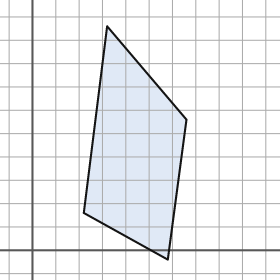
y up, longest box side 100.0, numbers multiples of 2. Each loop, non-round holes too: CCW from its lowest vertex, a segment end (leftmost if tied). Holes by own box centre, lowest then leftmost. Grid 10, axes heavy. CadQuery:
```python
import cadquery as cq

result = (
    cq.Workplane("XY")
    .moveTo(58.0, -4.0)
    .lineTo(66.0, 56.0)
    .lineTo(32.0, 96.0)
    .lineTo(22.0, 16.0)
    .close()
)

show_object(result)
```